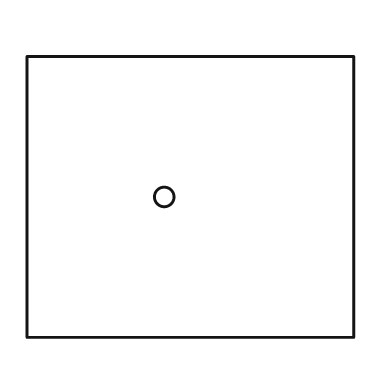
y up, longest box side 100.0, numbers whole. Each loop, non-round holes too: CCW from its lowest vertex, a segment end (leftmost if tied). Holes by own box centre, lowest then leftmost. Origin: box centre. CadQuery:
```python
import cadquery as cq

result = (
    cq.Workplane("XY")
    .moveTo(-50.0, -43.0)
    .lineTo(50.0, -43.0)
    .lineTo(50.0, 43.0)
    .lineTo(-50.0, 43.0)
    .close()
    .moveTo(-8.0, 0.0)
    .circle(3.0)
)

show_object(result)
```